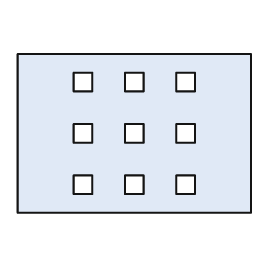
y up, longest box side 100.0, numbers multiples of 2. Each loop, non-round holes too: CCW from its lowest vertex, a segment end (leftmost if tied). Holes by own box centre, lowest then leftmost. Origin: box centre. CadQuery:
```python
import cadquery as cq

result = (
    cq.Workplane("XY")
    .moveTo(-50.0, -34.0)
    .lineTo(50.0, -34.0)
    .lineTo(50.0, 34.0)
    .lineTo(-50.0, 34.0)
    .close()
    .moveTo(-26.0, -26.0)
    .lineTo(-18.0, -26.0)
    .lineTo(-18.0, -18.0)
    .lineTo(-26.0, -18.0)
    .close()
    .moveTo(-4.0, -26.0)
    .lineTo(4.0, -26.0)
    .lineTo(4.0, -18.0)
    .lineTo(-4.0, -18.0)
    .close()
    .moveTo(18.0, -26.0)
    .lineTo(26.0, -26.0)
    .lineTo(26.0, -18.0)
    .lineTo(18.0, -18.0)
    .close()
    .moveTo(-26.0, -4.0)
    .lineTo(-18.0, -4.0)
    .lineTo(-18.0, 4.0)
    .lineTo(-26.0, 4.0)
    .close()
    .moveTo(-4.0, -4.0)
    .lineTo(4.0, -4.0)
    .lineTo(4.0, 4.0)
    .lineTo(-4.0, 4.0)
    .close()
    .moveTo(18.0, -4.0)
    .lineTo(26.0, -4.0)
    .lineTo(26.0, 4.0)
    .lineTo(18.0, 4.0)
    .close()
    .moveTo(-26.0, 18.0)
    .lineTo(-18.0, 18.0)
    .lineTo(-18.0, 26.0)
    .lineTo(-26.0, 26.0)
    .close()
    .moveTo(-4.0, 18.0)
    .lineTo(4.0, 18.0)
    .lineTo(4.0, 26.0)
    .lineTo(-4.0, 26.0)
    .close()
    .moveTo(18.0, 18.0)
    .lineTo(26.0, 18.0)
    .lineTo(26.0, 26.0)
    .lineTo(18.0, 26.0)
    .close()
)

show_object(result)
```